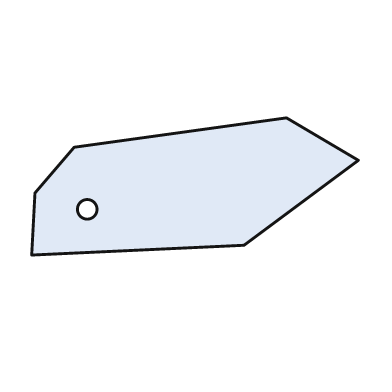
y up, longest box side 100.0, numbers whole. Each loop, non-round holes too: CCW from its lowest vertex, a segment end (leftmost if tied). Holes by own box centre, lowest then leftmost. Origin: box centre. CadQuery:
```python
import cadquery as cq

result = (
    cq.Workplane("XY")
    .moveTo(-50.0, -21.0)
    .lineTo(15.0, -18.0)
    .lineTo(50.0, 8.0)
    .lineTo(28.0, 21.0)
    .lineTo(-37.0, 12.0)
    .lineTo(-49.0, -2.0)
    .close()
    .moveTo(-33.0, -7.0)
    .circle(3.0)
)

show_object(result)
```